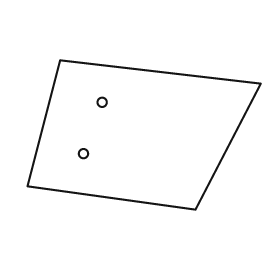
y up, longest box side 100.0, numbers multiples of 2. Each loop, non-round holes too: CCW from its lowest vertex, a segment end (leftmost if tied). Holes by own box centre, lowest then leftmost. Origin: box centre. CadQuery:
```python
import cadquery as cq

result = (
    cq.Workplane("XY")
    .moveTo(22.0, -32.0)
    .lineTo(50.0, 22.0)
    .lineTo(-36.0, 32.0)
    .lineTo(-50.0, -22.0)
    .close()
    .moveTo(-26.0, -8.0)
    .circle(2.0)
    .moveTo(-18.0, 14.0)
    .circle(2.0)
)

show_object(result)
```